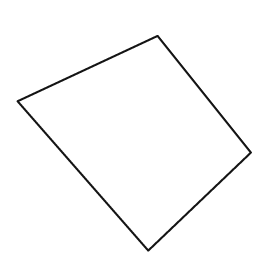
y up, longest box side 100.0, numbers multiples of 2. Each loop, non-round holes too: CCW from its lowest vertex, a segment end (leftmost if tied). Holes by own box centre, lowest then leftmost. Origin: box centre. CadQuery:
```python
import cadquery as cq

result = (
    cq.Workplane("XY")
    .moveTo(6.0, -46.0)
    .lineTo(50.0, -4.0)
    .lineTo(10.0, 46.0)
    .lineTo(-50.0, 18.0)
    .close()
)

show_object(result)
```